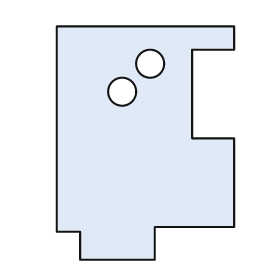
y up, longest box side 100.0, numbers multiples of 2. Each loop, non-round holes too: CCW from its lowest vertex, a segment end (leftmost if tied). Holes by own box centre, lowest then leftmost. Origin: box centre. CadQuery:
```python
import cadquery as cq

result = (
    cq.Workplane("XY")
    .moveTo(-28.0, -50.0)
    .lineTo(4.0, -50.0)
    .lineTo(4.0, -36.0)
    .lineTo(38.0, -36.0)
    .lineTo(38.0, 2.0)
    .lineTo(20.0, 2.0)
    .lineTo(20.0, 40.0)
    .lineTo(38.0, 40.0)
    .lineTo(38.0, 50.0)
    .lineTo(-38.0, 50.0)
    .lineTo(-38.0, -38.0)
    .lineTo(-28.0, -38.0)
    .close()
    .moveTo(-10.0, 22.0)
    .circle(6.0)
    .moveTo(2.0, 34.0)
    .circle(6.0)
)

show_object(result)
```